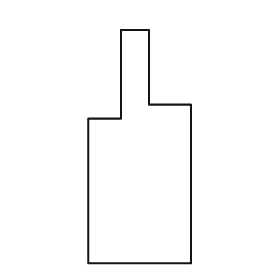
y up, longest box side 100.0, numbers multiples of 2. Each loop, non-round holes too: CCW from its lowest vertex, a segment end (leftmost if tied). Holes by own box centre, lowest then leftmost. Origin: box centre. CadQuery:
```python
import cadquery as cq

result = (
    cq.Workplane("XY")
    .moveTo(-22.0, -50.0)
    .lineTo(22.0, -50.0)
    .lineTo(22.0, 18.0)
    .lineTo(4.0, 18.0)
    .lineTo(4.0, 50.0)
    .lineTo(-8.0, 50.0)
    .lineTo(-8.0, 12.0)
    .lineTo(-22.0, 12.0)
    .close()
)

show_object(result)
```